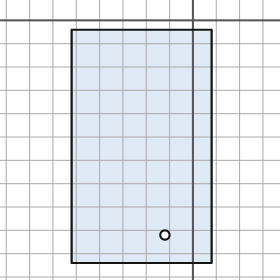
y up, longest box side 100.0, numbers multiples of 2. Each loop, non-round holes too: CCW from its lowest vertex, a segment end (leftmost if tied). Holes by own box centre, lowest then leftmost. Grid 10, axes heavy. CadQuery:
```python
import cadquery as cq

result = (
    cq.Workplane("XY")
    .moveTo(-52.0, -104.0)
    .lineTo(8.0, -104.0)
    .lineTo(8.0, -4.0)
    .lineTo(-52.0, -4.0)
    .close()
    .moveTo(-12.0, -92.0)
    .circle(2.0)
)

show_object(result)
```